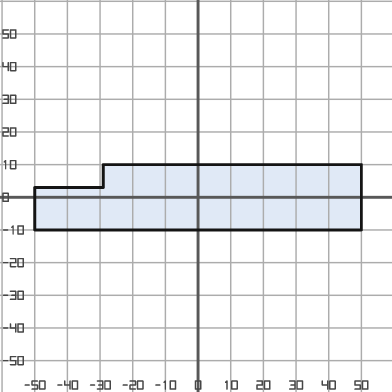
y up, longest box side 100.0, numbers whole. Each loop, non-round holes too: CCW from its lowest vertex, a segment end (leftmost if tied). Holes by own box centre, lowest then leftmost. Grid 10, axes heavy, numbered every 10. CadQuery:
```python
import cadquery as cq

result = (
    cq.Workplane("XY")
    .moveTo(-50.0, -10.0)
    .lineTo(50.0, -10.0)
    .lineTo(50.0, 10.0)
    .lineTo(-29.0, 10.0)
    .lineTo(-29.0, 3.0)
    .lineTo(-50.0, 3.0)
    .close()
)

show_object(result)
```